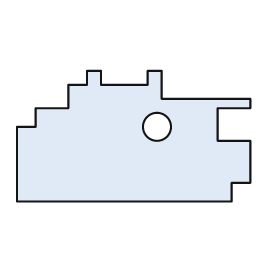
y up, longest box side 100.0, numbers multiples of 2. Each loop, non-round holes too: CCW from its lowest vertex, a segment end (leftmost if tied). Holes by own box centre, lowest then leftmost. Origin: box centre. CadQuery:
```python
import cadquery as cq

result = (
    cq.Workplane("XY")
    .moveTo(-50.0, -28.0)
    .lineTo(42.0, -28.0)
    .lineTo(42.0, -20.0)
    .lineTo(50.0, -20.0)
    .lineTo(50.0, -2.0)
    .lineTo(36.0, -2.0)
    .lineTo(36.0, 12.0)
    .lineTo(50.0, 12.0)
    .lineTo(50.0, 16.0)
    .lineTo(12.0, 16.0)
    .lineTo(12.0, 28.0)
    .lineTo(6.0, 28.0)
    .lineTo(6.0, 22.0)
    .lineTo(-14.0, 22.0)
    .lineTo(-14.0, 28.0)
    .lineTo(-20.0, 28.0)
    .lineTo(-20.0, 22.0)
    .lineTo(-28.0, 22.0)
    .lineTo(-28.0, 12.0)
    .lineTo(-42.0, 12.0)
    .lineTo(-42.0, 4.0)
    .lineTo(-50.0, 4.0)
    .close()
    .moveTo(10.0, 4.0)
    .circle(6.0)
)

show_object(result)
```